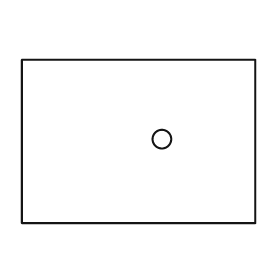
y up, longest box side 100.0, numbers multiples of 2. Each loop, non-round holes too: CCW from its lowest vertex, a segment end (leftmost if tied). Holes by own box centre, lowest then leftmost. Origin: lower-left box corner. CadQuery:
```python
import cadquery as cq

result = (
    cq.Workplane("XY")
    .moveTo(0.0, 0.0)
    .lineTo(100.0, 0.0)
    .lineTo(100.0, 70.0)
    .lineTo(0.0, 70.0)
    .close()
    .moveTo(60.0, 36.0)
    .circle(4.0)
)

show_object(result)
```